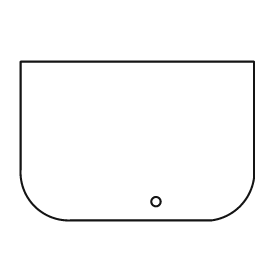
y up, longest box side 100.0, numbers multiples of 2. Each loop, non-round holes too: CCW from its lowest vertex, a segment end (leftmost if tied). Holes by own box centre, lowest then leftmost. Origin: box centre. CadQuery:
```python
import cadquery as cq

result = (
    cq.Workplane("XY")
    .moveTo(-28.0, -34.0)
    .lineTo(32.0, -34.0)
    .threePointArc((44.0, -28.0), (50.0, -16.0))
    .lineTo(50.0, 34.0)
    .lineTo(-50.0, 34.0)
    .lineTo(-50.0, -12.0)
    .threePointArc((-44.0, -28.0), (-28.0, -34.0))
    .close()
    .moveTo(8.0, -26.0)
    .circle(2.0)
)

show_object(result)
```